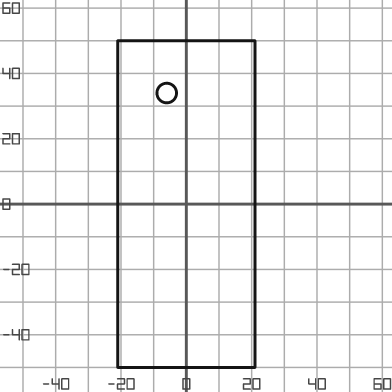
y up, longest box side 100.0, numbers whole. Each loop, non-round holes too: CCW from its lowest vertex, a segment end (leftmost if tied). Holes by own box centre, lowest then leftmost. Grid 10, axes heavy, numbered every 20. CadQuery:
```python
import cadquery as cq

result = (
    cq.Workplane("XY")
    .moveTo(-21.0, -50.0)
    .lineTo(21.0, -50.0)
    .lineTo(21.0, 50.0)
    .lineTo(-21.0, 50.0)
    .close()
    .moveTo(-6.0, 34.0)
    .circle(3.0)
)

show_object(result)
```